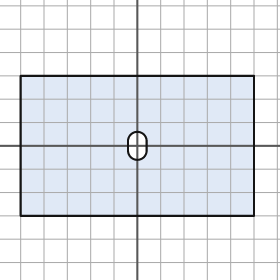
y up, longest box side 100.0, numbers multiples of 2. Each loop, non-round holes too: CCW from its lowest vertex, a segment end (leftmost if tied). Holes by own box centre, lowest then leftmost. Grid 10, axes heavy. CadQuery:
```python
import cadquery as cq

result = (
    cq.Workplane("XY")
    .moveTo(-50.0, -30.0)
    .lineTo(50.0, -30.0)
    .lineTo(50.0, 30.0)
    .lineTo(-50.0, 30.0)
    .close()
    .moveTo(-4.0, -2.0)
    .threePointArc((0.0, -6.0), (4.0, -2.0))
    .lineTo(4.0, 2.0)
    .threePointArc((0.0, 6.0), (-4.0, 2.0))
    .close()
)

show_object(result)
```